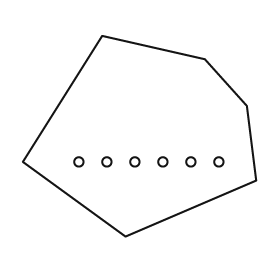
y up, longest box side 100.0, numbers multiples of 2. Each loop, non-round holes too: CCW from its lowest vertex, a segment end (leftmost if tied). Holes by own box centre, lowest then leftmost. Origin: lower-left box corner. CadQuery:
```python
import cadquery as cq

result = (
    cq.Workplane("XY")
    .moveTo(44.0, 0.0)
    .lineTo(100.0, 24.0)
    .lineTo(96.0, 56.0)
    .lineTo(78.0, 76.0)
    .lineTo(34.0, 86.0)
    .lineTo(0.0, 32.0)
    .close()
    .moveTo(24.0, 32.0)
    .circle(2.0)
    .moveTo(36.0, 32.0)
    .circle(2.0)
    .moveTo(48.0, 32.0)
    .circle(2.0)
    .moveTo(60.0, 32.0)
    .circle(2.0)
    .moveTo(72.0, 32.0)
    .circle(2.0)
    .moveTo(84.0, 32.0)
    .circle(2.0)
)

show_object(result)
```